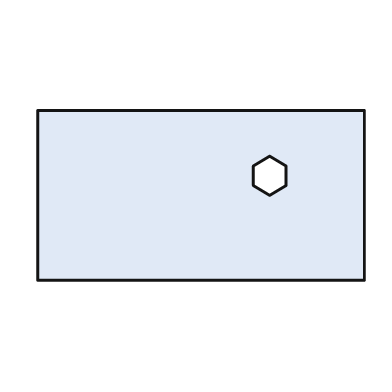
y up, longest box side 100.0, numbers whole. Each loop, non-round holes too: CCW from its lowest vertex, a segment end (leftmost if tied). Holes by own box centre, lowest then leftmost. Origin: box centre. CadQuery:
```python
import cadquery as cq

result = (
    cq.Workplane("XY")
    .moveTo(-50.0, -26.0)
    .lineTo(50.0, -26.0)
    .lineTo(50.0, 26.0)
    .lineTo(-50.0, 26.0)
    .close()
    .moveTo(21.0, 0.0)
    .lineTo(26.0, 3.0)
    .lineTo(26.0, 9.0)
    .lineTo(21.0, 12.0)
    .lineTo(16.0, 9.0)
    .lineTo(16.0, 3.0)
    .close()
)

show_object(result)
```